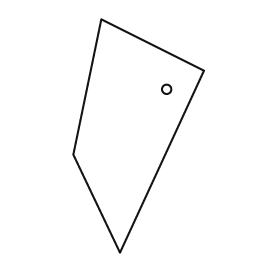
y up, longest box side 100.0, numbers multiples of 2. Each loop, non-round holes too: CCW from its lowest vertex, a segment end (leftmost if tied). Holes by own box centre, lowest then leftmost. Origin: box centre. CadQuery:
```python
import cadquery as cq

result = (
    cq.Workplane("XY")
    .moveTo(-8.0, -50.0)
    .lineTo(28.0, 28.0)
    .lineTo(-16.0, 50.0)
    .lineTo(-28.0, -8.0)
    .close()
    .moveTo(12.0, 20.0)
    .circle(2.0)
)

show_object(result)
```